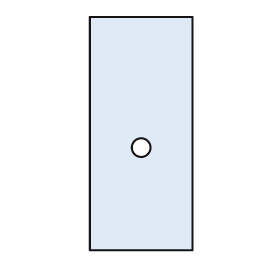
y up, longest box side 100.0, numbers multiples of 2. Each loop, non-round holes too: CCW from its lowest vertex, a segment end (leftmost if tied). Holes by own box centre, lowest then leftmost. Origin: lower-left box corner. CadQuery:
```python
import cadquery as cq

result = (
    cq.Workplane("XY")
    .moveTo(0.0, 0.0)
    .lineTo(44.0, 0.0)
    .lineTo(44.0, 100.0)
    .lineTo(0.0, 100.0)
    .close()
    .moveTo(22.0, 44.0)
    .circle(4.0)
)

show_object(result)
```